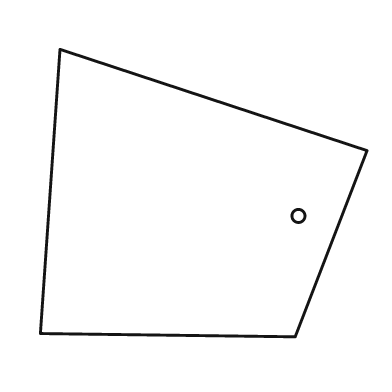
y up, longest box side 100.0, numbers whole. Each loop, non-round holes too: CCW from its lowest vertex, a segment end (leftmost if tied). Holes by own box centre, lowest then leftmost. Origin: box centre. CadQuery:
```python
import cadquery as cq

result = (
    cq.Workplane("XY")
    .moveTo(28.0, -44.0)
    .lineTo(50.0, 13.0)
    .lineTo(-44.0, 44.0)
    .lineTo(-50.0, -43.0)
    .close()
    .moveTo(29.0, -7.0)
    .circle(2.0)
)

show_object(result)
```